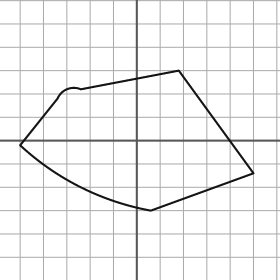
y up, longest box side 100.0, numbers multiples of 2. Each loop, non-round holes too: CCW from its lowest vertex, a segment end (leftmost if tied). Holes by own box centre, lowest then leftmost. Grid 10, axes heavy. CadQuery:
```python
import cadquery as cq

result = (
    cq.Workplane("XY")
    .moveTo(6.0, -30.0)
    .lineTo(50.0, -14.0)
    .lineTo(18.0, 30.0)
    .lineTo(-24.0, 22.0)
    .threePointArc((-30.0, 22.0), (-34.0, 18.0))
    .lineTo(-50.0, -2.0)
    .threePointArc((-24.0, -20.0), (6.0, -30.0))
    .close()
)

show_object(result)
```